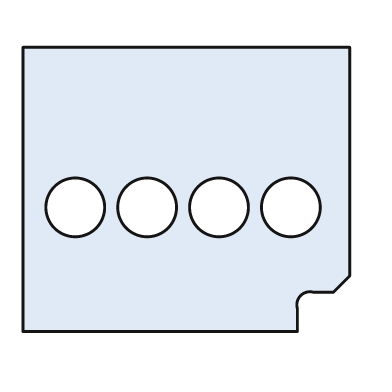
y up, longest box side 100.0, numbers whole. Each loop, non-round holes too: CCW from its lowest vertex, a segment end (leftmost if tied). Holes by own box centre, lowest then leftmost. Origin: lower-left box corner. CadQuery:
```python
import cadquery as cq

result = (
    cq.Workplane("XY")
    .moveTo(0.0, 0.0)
    .lineTo(84.0, 0.0)
    .lineTo(84.0, 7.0)
    .threePointArc((85.0, 11.0), (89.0, 12.0))
    .lineTo(95.0, 12.0)
    .lineTo(100.0, 17.0)
    .lineTo(100.0, 87.0)
    .lineTo(0.0, 87.0)
    .close()
    .moveTo(16.0, 38.0)
    .circle(9.0)
    .moveTo(38.0, 38.0)
    .circle(9.0)
    .moveTo(60.0, 38.0)
    .circle(9.0)
    .moveTo(82.0, 38.0)
    .circle(9.0)
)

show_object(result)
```